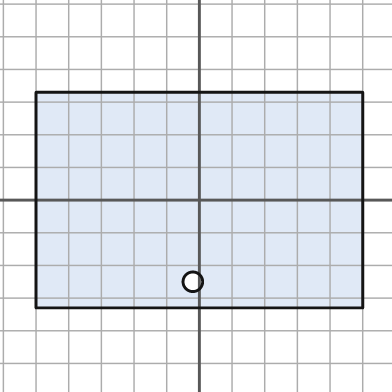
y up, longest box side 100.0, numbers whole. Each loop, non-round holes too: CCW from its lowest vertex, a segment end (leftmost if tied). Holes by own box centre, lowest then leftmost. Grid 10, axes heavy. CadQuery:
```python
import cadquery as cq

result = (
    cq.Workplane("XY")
    .moveTo(-50.0, -33.0)
    .lineTo(50.0, -33.0)
    .lineTo(50.0, 33.0)
    .lineTo(-50.0, 33.0)
    .close()
    .moveTo(-2.0, -25.0)
    .circle(3.0)
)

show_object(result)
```